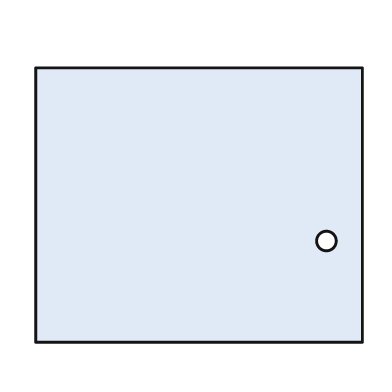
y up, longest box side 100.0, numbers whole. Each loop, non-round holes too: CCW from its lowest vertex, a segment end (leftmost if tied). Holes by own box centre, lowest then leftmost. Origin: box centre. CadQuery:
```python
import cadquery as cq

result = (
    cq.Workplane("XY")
    .moveTo(-50.0, -42.0)
    .lineTo(50.0, -42.0)
    .lineTo(50.0, 42.0)
    .lineTo(-50.0, 42.0)
    .close()
    .moveTo(39.0, -11.0)
    .circle(3.0)
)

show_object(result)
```